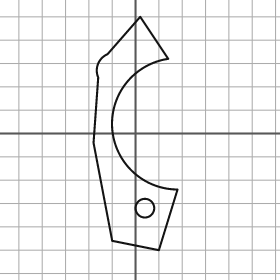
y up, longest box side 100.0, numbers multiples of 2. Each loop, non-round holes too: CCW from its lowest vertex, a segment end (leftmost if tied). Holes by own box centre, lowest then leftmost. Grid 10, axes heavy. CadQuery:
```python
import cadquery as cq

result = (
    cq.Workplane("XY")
    .moveTo(10.0, -50.0)
    .lineTo(18.0, -24.0)
    .threePointArc((-10.0, 2.0), (14.0, 32.0))
    .lineTo(2.0, 50.0)
    .lineTo(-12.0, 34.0)
    .threePointArc((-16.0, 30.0), (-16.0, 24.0))
    .lineTo(-18.0, -4.0)
    .lineTo(-10.0, -46.0)
    .close()
    .moveTo(4.0, -32.0)
    .circle(4.0)
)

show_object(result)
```